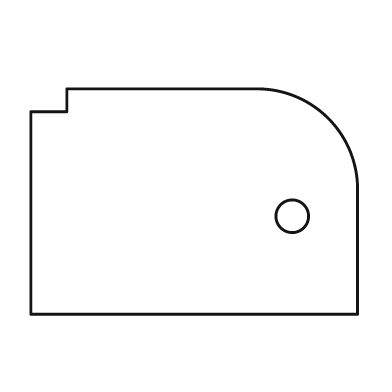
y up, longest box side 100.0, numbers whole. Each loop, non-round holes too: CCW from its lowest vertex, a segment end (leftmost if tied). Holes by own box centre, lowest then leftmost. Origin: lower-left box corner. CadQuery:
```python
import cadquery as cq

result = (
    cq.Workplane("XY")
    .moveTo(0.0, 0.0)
    .lineTo(100.0, 0.0)
    .lineTo(100.0, 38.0)
    .threePointArc((91.0, 60.0), (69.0, 69.0))
    .lineTo(11.0, 69.0)
    .lineTo(11.0, 62.0)
    .lineTo(0.0, 62.0)
    .close()
    .moveTo(80.0, 30.0)
    .circle(5.0)
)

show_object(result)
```